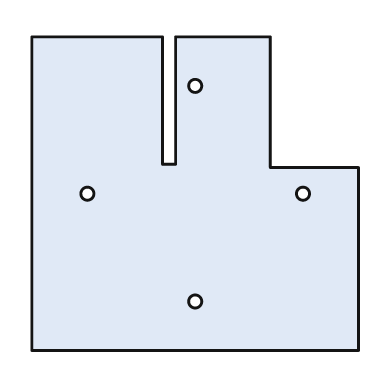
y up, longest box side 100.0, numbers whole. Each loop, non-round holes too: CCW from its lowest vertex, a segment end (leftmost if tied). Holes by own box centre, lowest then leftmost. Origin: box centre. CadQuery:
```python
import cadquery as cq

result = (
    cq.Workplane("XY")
    .moveTo(-50.0, -48.0)
    .lineTo(50.0, -48.0)
    .lineTo(50.0, 8.0)
    .lineTo(23.0, 8.0)
    .lineTo(23.0, 48.0)
    .lineTo(-6.0, 48.0)
    .lineTo(-6.0, 9.0)
    .lineTo(-10.0, 9.0)
    .lineTo(-10.0, 48.0)
    .lineTo(-50.0, 48.0)
    .close()
    .moveTo(0.0, -33.0)
    .circle(2.0)
    .moveTo(-33.0, 0.0)
    .circle(2.0)
    .moveTo(33.0, 0.0)
    .circle(2.0)
    .moveTo(0.0, 33.0)
    .circle(2.0)
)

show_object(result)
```